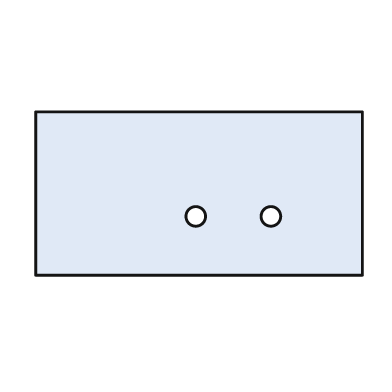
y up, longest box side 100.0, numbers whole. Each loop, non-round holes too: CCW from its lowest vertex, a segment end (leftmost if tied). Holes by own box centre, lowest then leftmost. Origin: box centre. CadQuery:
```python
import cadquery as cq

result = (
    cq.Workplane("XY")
    .moveTo(-50.0, -25.0)
    .lineTo(50.0, -25.0)
    .lineTo(50.0, 25.0)
    .lineTo(-50.0, 25.0)
    .close()
    .moveTo(-1.0, -7.0)
    .circle(3.0)
    .moveTo(22.0, -7.0)
    .circle(3.0)
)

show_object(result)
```